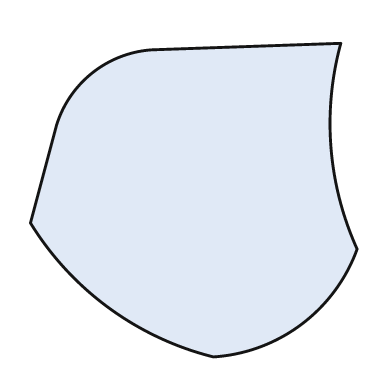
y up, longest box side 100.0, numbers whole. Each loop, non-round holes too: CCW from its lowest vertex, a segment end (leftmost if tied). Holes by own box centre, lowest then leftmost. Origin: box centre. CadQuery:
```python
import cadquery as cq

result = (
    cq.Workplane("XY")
    .moveTo(6.0, -48.0)
    .threePointArc((33.0, -38.0), (50.0, -15.0))
    .threePointArc((42.0, 16.0), (45.0, 48.0))
    .lineTo(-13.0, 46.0)
    .threePointArc((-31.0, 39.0), (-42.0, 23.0))
    .lineTo(-50.0, -7.0)
    .threePointArc((-26.0, -33.0), (6.0, -48.0))
    .close()
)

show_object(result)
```